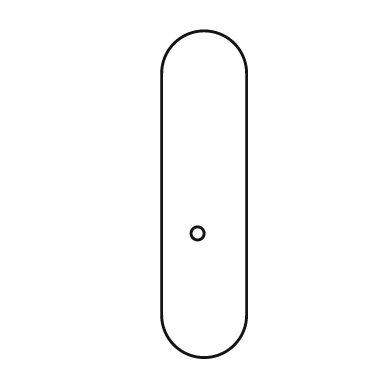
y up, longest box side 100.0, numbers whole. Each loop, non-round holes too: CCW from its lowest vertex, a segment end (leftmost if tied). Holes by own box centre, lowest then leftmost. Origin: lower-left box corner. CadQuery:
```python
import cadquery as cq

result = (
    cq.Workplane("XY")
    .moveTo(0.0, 13.0)
    .threePointArc((13.0, 0.0), (26.0, 13.0))
    .lineTo(26.0, 87.0)
    .threePointArc((13.0, 100.0), (0.0, 87.0))
    .close()
    .moveTo(11.0, 38.0)
    .circle(2.0)
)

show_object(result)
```